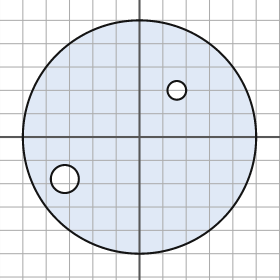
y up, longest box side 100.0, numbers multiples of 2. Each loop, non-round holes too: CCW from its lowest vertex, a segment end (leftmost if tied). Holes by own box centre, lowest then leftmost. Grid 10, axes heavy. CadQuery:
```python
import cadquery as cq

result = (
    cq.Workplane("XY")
    .moveTo(0.0, 0.0)
    .circle(50.0)
    .moveTo(-32.0, -18.0)
    .circle(6.0)
    .moveTo(16.0, 20.0)
    .circle(4.0)
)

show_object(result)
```